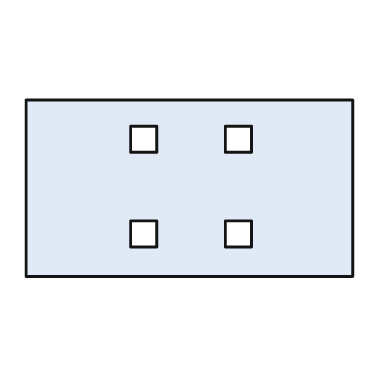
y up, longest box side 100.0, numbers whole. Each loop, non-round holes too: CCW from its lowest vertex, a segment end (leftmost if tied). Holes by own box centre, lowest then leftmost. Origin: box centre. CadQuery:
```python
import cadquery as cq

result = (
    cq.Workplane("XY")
    .moveTo(-50.0, -27.0)
    .lineTo(50.0, -27.0)
    .lineTo(50.0, 27.0)
    .lineTo(-50.0, 27.0)
    .close()
    .moveTo(-18.0, -18.0)
    .lineTo(-10.0, -18.0)
    .lineTo(-10.0, -10.0)
    .lineTo(-18.0, -10.0)
    .close()
    .moveTo(11.0, -18.0)
    .lineTo(19.0, -18.0)
    .lineTo(19.0, -10.0)
    .lineTo(11.0, -10.0)
    .close()
    .moveTo(-18.0, 11.0)
    .lineTo(-10.0, 11.0)
    .lineTo(-10.0, 19.0)
    .lineTo(-18.0, 19.0)
    .close()
    .moveTo(11.0, 11.0)
    .lineTo(19.0, 11.0)
    .lineTo(19.0, 19.0)
    .lineTo(11.0, 19.0)
    .close()
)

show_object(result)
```